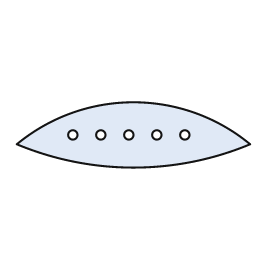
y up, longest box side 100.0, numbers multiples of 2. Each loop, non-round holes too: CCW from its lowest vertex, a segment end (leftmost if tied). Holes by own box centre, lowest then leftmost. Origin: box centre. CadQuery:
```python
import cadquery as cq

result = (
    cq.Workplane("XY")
    .moveTo(-50.0, -4.0)
    .threePointArc((0.0, -14.0), (50.0, -4.0))
    .threePointArc((0.0, 14.0), (-50.0, -4.0))
    .close()
    .moveTo(-26.0, 0.0)
    .circle(2.0)
    .moveTo(-14.0, 0.0)
    .circle(2.0)
    .moveTo(-2.0, 0.0)
    .circle(2.0)
    .moveTo(10.0, 0.0)
    .circle(2.0)
    .moveTo(22.0, 0.0)
    .circle(2.0)
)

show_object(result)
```